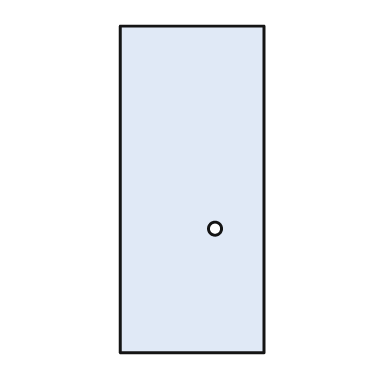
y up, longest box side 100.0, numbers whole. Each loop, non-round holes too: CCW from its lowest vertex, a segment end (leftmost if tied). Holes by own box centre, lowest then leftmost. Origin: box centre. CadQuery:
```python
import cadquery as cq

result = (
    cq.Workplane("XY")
    .moveTo(-22.0, -50.0)
    .lineTo(22.0, -50.0)
    .lineTo(22.0, 50.0)
    .lineTo(-22.0, 50.0)
    .close()
    .moveTo(7.0, -12.0)
    .circle(2.0)
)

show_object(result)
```